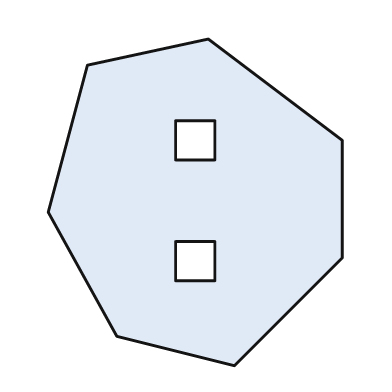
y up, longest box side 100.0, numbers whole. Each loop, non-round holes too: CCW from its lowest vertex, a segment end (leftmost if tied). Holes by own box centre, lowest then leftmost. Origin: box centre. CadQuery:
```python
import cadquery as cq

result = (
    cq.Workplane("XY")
    .moveTo(12.0, -50.0)
    .lineTo(45.0, -17.0)
    .lineTo(45.0, 19.0)
    .lineTo(4.0, 50.0)
    .lineTo(-33.0, 42.0)
    .lineTo(-45.0, -3.0)
    .lineTo(-24.0, -41.0)
    .close()
    .moveTo(-6.0, -24.0)
    .lineTo(6.0, -24.0)
    .lineTo(6.0, -12.0)
    .lineTo(-6.0, -12.0)
    .close()
    .moveTo(-6.0, 13.0)
    .lineTo(6.0, 13.0)
    .lineTo(6.0, 25.0)
    .lineTo(-6.0, 25.0)
    .close()
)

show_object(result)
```